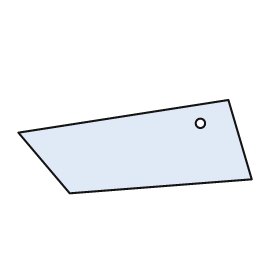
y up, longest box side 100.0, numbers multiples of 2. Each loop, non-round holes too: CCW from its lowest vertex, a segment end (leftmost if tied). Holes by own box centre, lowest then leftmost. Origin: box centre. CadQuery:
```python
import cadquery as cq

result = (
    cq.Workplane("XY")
    .moveTo(-28.0, -20.0)
    .lineTo(50.0, -14.0)
    .lineTo(40.0, 20.0)
    .lineTo(-50.0, 6.0)
    .close()
    .moveTo(28.0, 10.0)
    .circle(2.0)
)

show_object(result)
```